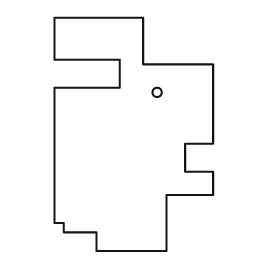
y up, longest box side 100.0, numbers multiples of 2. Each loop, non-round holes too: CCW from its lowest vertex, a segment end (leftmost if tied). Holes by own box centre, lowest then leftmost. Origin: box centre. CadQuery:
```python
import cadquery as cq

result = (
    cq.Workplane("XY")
    .moveTo(-16.0, -50.0)
    .lineTo(14.0, -50.0)
    .lineTo(14.0, -26.0)
    .lineTo(34.0, -26.0)
    .lineTo(34.0, -16.0)
    .lineTo(22.0, -16.0)
    .lineTo(22.0, -4.0)
    .lineTo(34.0, -4.0)
    .lineTo(34.0, 30.0)
    .lineTo(4.0, 30.0)
    .lineTo(4.0, 50.0)
    .lineTo(-34.0, 50.0)
    .lineTo(-34.0, 32.0)
    .lineTo(-6.0, 32.0)
    .lineTo(-6.0, 20.0)
    .lineTo(-34.0, 20.0)
    .lineTo(-34.0, -38.0)
    .lineTo(-30.0, -38.0)
    .lineTo(-30.0, -42.0)
    .lineTo(-16.0, -42.0)
    .close()
    .moveTo(10.0, 18.0)
    .circle(2.0)
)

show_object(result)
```